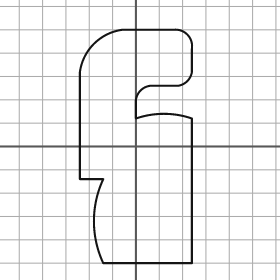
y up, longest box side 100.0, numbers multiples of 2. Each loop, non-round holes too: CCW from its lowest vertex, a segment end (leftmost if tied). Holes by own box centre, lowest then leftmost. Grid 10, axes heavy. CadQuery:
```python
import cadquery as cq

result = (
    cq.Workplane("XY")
    .moveTo(-14.0, -50.0)
    .lineTo(24.0, -50.0)
    .lineTo(24.0, 12.0)
    .threePointArc((12.0, 14.0), (0.0, 12.0))
    .lineTo(0.0, 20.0)
    .threePointArc((2.0, 24.0), (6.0, 26.0))
    .lineTo(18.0, 26.0)
    .threePointArc((22.0, 28.0), (24.0, 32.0))
    .lineTo(24.0, 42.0)
    .threePointArc((22.0, 48.0), (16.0, 50.0))
    .lineTo(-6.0, 50.0)
    .threePointArc((-18.0, 44.0), (-24.0, 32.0))
    .lineTo(-24.0, -14.0)
    .lineTo(-14.0, -14.0)
    .threePointArc((-18.0, -32.0), (-14.0, -50.0))
    .close()
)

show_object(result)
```